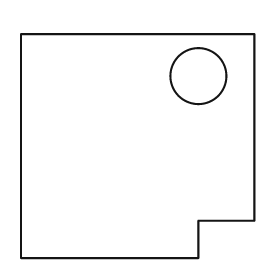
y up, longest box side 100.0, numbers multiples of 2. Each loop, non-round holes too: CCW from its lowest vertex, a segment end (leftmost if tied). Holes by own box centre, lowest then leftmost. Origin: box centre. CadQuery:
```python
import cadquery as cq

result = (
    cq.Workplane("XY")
    .moveTo(-50.0, -48.0)
    .lineTo(26.0, -48.0)
    .lineTo(26.0, -32.0)
    .lineTo(50.0, -32.0)
    .lineTo(50.0, 48.0)
    .lineTo(-50.0, 48.0)
    .close()
    .moveTo(26.0, 30.0)
    .circle(12.0)
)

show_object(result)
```